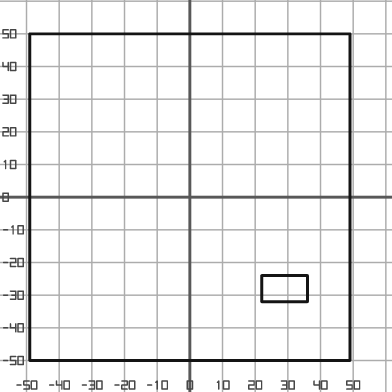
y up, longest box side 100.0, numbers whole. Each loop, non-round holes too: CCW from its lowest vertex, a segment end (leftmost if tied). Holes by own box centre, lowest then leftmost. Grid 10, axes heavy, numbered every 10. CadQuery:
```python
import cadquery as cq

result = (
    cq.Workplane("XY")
    .moveTo(-49.0, -50.0)
    .lineTo(49.0, -50.0)
    .lineTo(49.0, 50.0)
    .lineTo(-49.0, 50.0)
    .close()
    .moveTo(22.0, -32.0)
    .lineTo(36.0, -32.0)
    .lineTo(36.0, -24.0)
    .lineTo(22.0, -24.0)
    .close()
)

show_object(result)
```